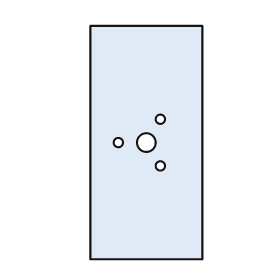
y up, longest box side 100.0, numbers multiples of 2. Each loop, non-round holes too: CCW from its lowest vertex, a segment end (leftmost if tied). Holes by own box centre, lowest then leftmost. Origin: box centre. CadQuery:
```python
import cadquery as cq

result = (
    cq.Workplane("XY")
    .moveTo(-24.0, -50.0)
    .lineTo(24.0, -50.0)
    .lineTo(24.0, 50.0)
    .lineTo(-24.0, 50.0)
    .close()
    .moveTo(6.0, -10.0)
    .circle(2.0)
    .moveTo(-12.0, 0.0)
    .circle(2.0)
    .moveTo(0.0, 0.0)
    .circle(4.0)
    .moveTo(6.0, 10.0)
    .circle(2.0)
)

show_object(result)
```